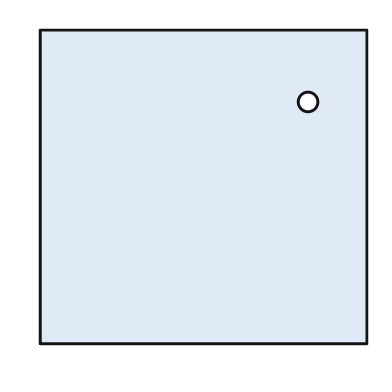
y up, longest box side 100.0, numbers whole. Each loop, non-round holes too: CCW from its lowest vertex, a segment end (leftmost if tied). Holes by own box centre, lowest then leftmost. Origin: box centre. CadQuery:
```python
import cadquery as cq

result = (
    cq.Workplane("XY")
    .moveTo(-50.0, -48.0)
    .lineTo(50.0, -48.0)
    .lineTo(50.0, 48.0)
    .lineTo(-50.0, 48.0)
    .close()
    .moveTo(32.0, 26.0)
    .circle(3.0)
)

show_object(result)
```